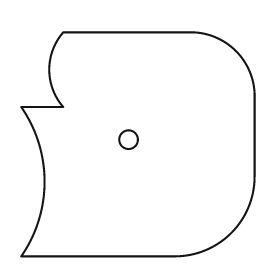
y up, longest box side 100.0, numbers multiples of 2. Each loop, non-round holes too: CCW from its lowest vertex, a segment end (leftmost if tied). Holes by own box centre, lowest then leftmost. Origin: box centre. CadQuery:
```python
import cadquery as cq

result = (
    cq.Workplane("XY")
    .moveTo(-50.0, -48.0)
    .lineTo(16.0, -48.0)
    .threePointArc((40.0, -38.0), (50.0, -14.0))
    .lineTo(50.0, 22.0)
    .threePointArc((42.0, 40.0), (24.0, 48.0))
    .lineTo(-32.0, 48.0)
    .threePointArc((-38.0, 32.0), (-32.0, 16.0))
    .lineTo(-50.0, 16.0)
    .threePointArc((-40.0, -16.0), (-50.0, -48.0))
    .close()
    .moveTo(-4.0, 2.0)
    .circle(4.0)
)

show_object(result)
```